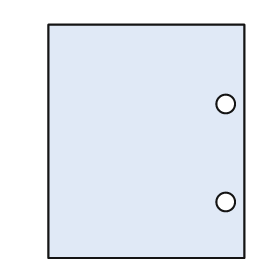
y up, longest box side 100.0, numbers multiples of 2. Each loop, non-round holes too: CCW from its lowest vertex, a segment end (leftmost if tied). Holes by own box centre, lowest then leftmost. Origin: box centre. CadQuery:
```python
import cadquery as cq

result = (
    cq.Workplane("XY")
    .moveTo(-42.0, -50.0)
    .lineTo(42.0, -50.0)
    .lineTo(42.0, 50.0)
    .lineTo(-42.0, 50.0)
    .close()
    .moveTo(34.0, -26.0)
    .circle(4.0)
    .moveTo(34.0, 16.0)
    .circle(4.0)
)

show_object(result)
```